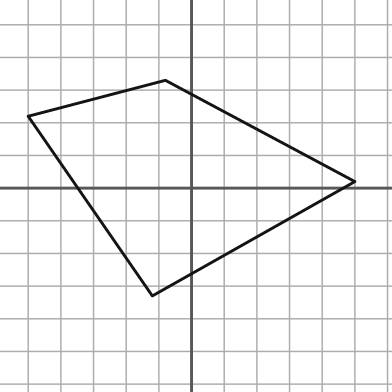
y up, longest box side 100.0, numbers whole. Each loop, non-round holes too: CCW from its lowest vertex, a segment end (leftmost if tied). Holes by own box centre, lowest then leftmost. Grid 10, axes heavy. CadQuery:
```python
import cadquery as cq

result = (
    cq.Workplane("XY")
    .moveTo(-12.0, -33.0)
    .lineTo(50.0, 2.0)
    .lineTo(-8.0, 33.0)
    .lineTo(-50.0, 22.0)
    .close()
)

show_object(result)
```